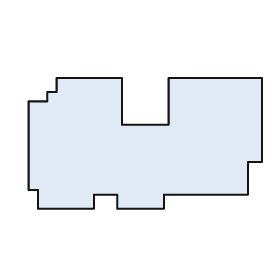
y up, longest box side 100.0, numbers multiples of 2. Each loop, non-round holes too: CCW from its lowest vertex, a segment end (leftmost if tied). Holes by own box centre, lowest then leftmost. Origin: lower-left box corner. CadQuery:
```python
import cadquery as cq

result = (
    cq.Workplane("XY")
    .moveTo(4.0, 0.0)
    .lineTo(28.0, 0.0)
    .lineTo(28.0, 6.0)
    .lineTo(38.0, 6.0)
    .lineTo(38.0, 0.0)
    .lineTo(58.0, 0.0)
    .lineTo(58.0, 6.0)
    .lineTo(94.0, 6.0)
    .lineTo(94.0, 20.0)
    .lineTo(100.0, 20.0)
    .lineTo(100.0, 56.0)
    .lineTo(60.0, 56.0)
    .lineTo(60.0, 36.0)
    .lineTo(40.0, 36.0)
    .lineTo(40.0, 56.0)
    .lineTo(12.0, 56.0)
    .lineTo(12.0, 50.0)
    .lineTo(8.0, 50.0)
    .lineTo(8.0, 46.0)
    .lineTo(0.0, 46.0)
    .lineTo(0.0, 8.0)
    .lineTo(4.0, 8.0)
    .close()
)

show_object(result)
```